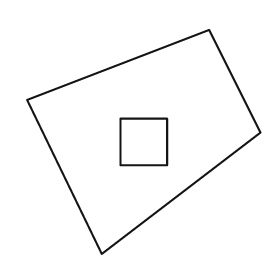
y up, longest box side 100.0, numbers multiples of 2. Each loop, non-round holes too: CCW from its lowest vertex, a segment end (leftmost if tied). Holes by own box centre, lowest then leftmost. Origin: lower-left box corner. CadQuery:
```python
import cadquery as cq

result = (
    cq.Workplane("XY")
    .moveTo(32.0, 0.0)
    .lineTo(100.0, 52.0)
    .lineTo(78.0, 96.0)
    .lineTo(0.0, 66.0)
    .close()
    .moveTo(40.0, 38.0)
    .lineTo(60.0, 38.0)
    .lineTo(60.0, 58.0)
    .lineTo(40.0, 58.0)
    .close()
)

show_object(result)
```